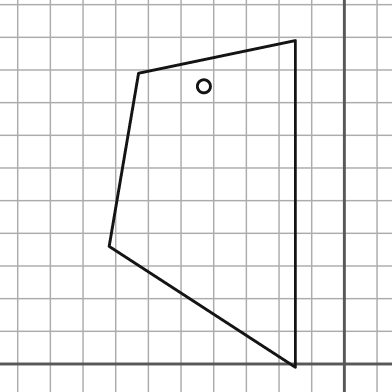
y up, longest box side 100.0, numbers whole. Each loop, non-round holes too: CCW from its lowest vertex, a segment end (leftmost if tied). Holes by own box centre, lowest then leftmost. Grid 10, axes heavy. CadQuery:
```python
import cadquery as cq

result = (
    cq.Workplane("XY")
    .moveTo(-15.0, -1.0)
    .lineTo(-15.0, 99.0)
    .lineTo(-63.0, 89.0)
    .lineTo(-72.0, 36.0)
    .close()
    .moveTo(-43.0, 85.0)
    .circle(2.0)
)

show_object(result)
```